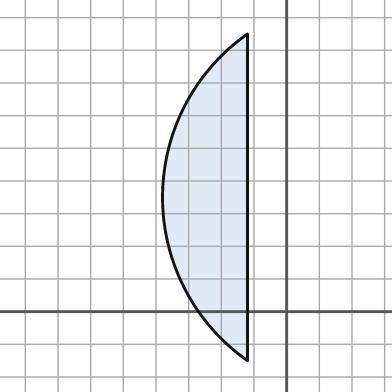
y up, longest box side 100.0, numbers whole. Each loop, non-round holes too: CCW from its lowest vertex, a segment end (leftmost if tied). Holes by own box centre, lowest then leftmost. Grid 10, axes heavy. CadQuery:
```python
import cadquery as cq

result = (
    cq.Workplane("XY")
    .moveTo(-12.0, -15.0)
    .lineTo(-12.0, 85.0)
    .threePointArc((-38.0, 35.0), (-12.0, -15.0))
    .close()
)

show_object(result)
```